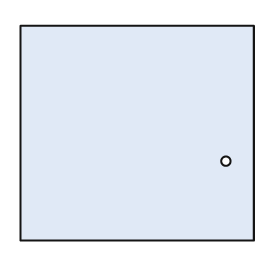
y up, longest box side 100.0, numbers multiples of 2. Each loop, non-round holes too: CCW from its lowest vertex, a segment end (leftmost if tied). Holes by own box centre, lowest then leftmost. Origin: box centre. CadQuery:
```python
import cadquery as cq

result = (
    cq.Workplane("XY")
    .moveTo(-50.0, -46.0)
    .lineTo(50.0, -46.0)
    .lineTo(50.0, 46.0)
    .lineTo(-50.0, 46.0)
    .close()
    .moveTo(38.0, -12.0)
    .circle(2.0)
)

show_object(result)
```